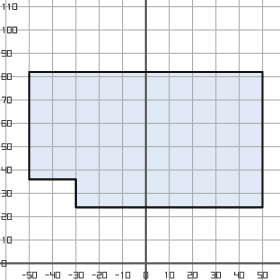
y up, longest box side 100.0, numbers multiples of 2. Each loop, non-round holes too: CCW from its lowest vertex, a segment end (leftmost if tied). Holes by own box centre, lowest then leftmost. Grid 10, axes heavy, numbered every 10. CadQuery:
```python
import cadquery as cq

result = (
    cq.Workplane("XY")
    .moveTo(-30.0, 24.0)
    .lineTo(50.0, 24.0)
    .lineTo(50.0, 82.0)
    .lineTo(-50.0, 82.0)
    .lineTo(-50.0, 36.0)
    .lineTo(-30.0, 36.0)
    .close()
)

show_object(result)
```